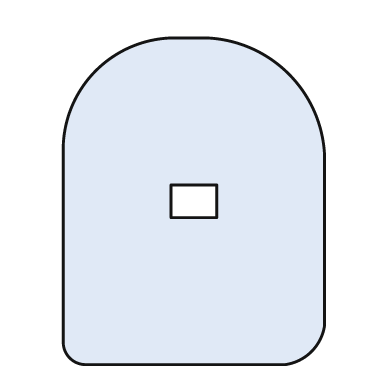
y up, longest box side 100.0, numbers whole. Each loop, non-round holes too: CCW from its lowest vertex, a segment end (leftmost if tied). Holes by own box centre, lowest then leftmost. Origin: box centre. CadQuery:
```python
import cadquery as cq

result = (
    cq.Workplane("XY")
    .moveTo(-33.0, -50.0)
    .lineTo(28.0, -50.0)
    .threePointArc((36.0, -46.0), (40.0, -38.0))
    .lineTo(40.0, 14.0)
    .threePointArc((29.0, 39.0), (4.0, 50.0))
    .lineTo(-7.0, 50.0)
    .threePointArc((-30.0, 40.0), (-40.0, 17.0))
    .lineTo(-40.0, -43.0)
    .threePointArc((-38.0, -48.0), (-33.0, -50.0))
    .close()
    .moveTo(-7.0, -5.0)
    .lineTo(7.0, -5.0)
    .lineTo(7.0, 5.0)
    .lineTo(-7.0, 5.0)
    .close()
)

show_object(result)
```